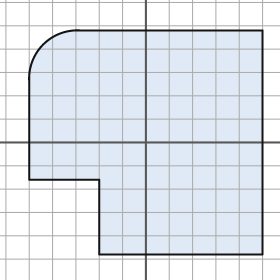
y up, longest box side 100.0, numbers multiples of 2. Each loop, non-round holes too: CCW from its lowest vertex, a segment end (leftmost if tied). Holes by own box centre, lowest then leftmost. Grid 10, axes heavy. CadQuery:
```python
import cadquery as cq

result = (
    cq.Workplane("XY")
    .moveTo(-20.0, -48.0)
    .lineTo(50.0, -48.0)
    .lineTo(50.0, 48.0)
    .lineTo(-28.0, 48.0)
    .threePointArc((-44.0, 42.0), (-50.0, 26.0))
    .lineTo(-50.0, -16.0)
    .lineTo(-20.0, -16.0)
    .close()
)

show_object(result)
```